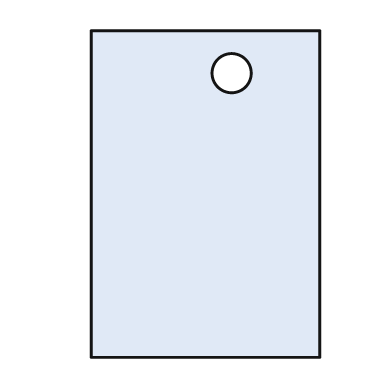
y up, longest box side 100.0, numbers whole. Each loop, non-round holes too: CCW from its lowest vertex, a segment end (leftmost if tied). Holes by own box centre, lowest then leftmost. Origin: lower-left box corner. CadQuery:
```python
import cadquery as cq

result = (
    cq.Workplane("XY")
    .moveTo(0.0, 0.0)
    .lineTo(70.0, 0.0)
    .lineTo(70.0, 100.0)
    .lineTo(0.0, 100.0)
    .close()
    .moveTo(43.0, 87.0)
    .circle(6.0)
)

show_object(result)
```